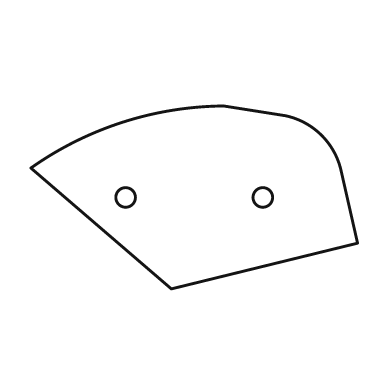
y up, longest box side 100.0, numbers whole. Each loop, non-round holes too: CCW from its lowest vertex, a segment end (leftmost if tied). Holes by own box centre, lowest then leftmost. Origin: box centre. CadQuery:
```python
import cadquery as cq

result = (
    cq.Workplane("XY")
    .moveTo(-7.0, -28.0)
    .lineTo(50.0, -14.0)
    .lineTo(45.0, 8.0)
    .threePointArc((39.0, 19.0), (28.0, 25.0))
    .lineTo(9.0, 28.0)
    .threePointArc((-22.0, 23.0), (-50.0, 9.0))
    .close()
    .moveTo(-21.0, 0.0)
    .circle(3.0)
    .moveTo(21.0, 0.0)
    .circle(3.0)
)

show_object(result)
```